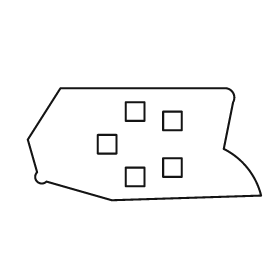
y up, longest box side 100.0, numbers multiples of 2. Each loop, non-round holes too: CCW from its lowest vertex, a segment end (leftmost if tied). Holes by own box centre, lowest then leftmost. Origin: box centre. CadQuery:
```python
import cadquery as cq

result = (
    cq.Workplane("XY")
    .moveTo(-14.0, -24.0)
    .lineTo(50.0, -22.0)
    .threePointArc((44.0, -10.0), (34.0, -2.0))
    .lineTo(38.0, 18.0)
    .threePointArc((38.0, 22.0), (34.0, 24.0))
    .lineTo(-36.0, 24.0)
    .lineTo(-50.0, 2.0)
    .lineTo(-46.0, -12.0)
    .threePointArc((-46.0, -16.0), (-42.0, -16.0))
    .close()
    .moveTo(-8.0, -18.0)
    .lineTo(0.0, -18.0)
    .lineTo(0.0, -10.0)
    .lineTo(-8.0, -10.0)
    .close()
    .moveTo(8.0, -14.0)
    .lineTo(16.0, -14.0)
    .lineTo(16.0, -6.0)
    .lineTo(8.0, -6.0)
    .close()
    .moveTo(-20.0, -4.0)
    .lineTo(-12.0, -4.0)
    .lineTo(-12.0, 4.0)
    .lineTo(-20.0, 4.0)
    .close()
    .moveTo(8.0, 6.0)
    .lineTo(16.0, 6.0)
    .lineTo(16.0, 14.0)
    .lineTo(8.0, 14.0)
    .close()
    .moveTo(-8.0, 10.0)
    .lineTo(0.0, 10.0)
    .lineTo(0.0, 18.0)
    .lineTo(-8.0, 18.0)
    .close()
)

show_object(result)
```